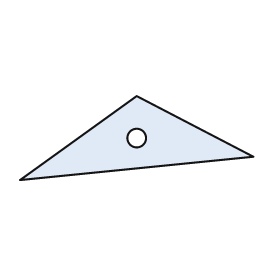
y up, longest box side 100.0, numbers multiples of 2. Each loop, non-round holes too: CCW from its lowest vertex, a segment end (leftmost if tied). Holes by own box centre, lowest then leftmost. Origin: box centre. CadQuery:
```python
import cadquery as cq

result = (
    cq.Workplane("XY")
    .moveTo(-50.0, -18.0)
    .lineTo(50.0, -8.0)
    .lineTo(0.0, 18.0)
    .close()
    .moveTo(0.0, 0.0)
    .circle(4.0)
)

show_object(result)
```